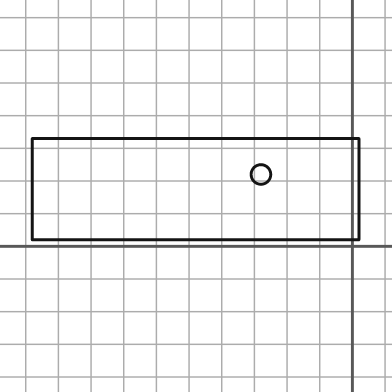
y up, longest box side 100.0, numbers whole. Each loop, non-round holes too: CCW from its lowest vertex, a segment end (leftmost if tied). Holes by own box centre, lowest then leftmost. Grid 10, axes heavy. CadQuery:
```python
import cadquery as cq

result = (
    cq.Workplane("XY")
    .moveTo(-98.0, 2.0)
    .lineTo(2.0, 2.0)
    .lineTo(2.0, 33.0)
    .lineTo(-98.0, 33.0)
    .close()
    .moveTo(-28.0, 22.0)
    .circle(3.0)
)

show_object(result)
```